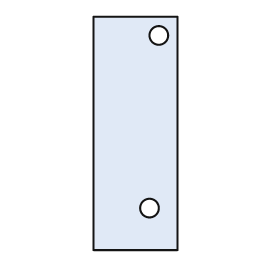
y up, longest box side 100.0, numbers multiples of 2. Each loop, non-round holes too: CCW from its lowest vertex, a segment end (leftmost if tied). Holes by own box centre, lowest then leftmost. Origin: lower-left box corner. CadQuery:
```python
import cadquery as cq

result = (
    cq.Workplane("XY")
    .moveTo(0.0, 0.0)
    .lineTo(36.0, 0.0)
    .lineTo(36.0, 100.0)
    .lineTo(0.0, 100.0)
    .close()
    .moveTo(24.0, 18.0)
    .circle(4.0)
    .moveTo(28.0, 92.0)
    .circle(4.0)
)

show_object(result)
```